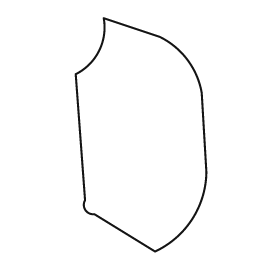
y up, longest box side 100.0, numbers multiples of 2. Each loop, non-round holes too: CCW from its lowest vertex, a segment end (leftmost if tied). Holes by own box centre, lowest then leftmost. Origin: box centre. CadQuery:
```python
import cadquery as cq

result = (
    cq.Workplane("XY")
    .moveTo(6.0, -50.0)
    .threePointArc((22.0, -36.0), (28.0, -16.0))
    .lineTo(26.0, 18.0)
    .threePointArc((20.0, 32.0), (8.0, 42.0))
    .lineTo(-16.0, 50.0)
    .threePointArc((-18.0, 36.0), (-28.0, 26.0))
    .lineTo(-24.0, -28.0)
    .threePointArc((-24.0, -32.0), (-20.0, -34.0))
    .close()
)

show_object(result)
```